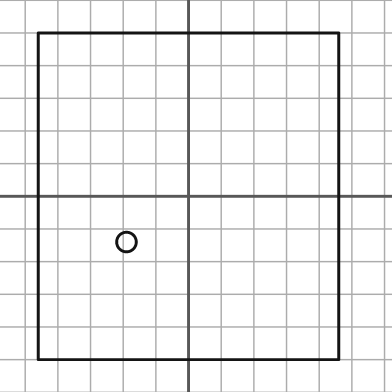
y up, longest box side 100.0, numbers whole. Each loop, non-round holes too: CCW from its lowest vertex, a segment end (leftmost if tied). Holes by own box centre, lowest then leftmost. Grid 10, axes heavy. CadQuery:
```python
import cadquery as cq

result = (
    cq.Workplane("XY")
    .moveTo(-46.0, -50.0)
    .lineTo(46.0, -50.0)
    .lineTo(46.0, 50.0)
    .lineTo(-46.0, 50.0)
    .close()
    .moveTo(-19.0, -14.0)
    .circle(3.0)
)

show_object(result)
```